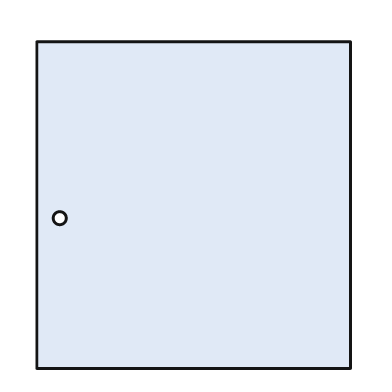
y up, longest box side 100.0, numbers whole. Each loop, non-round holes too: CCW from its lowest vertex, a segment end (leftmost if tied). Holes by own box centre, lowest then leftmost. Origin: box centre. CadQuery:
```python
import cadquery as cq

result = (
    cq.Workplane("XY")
    .moveTo(-48.0, -50.0)
    .lineTo(48.0, -50.0)
    .lineTo(48.0, 50.0)
    .lineTo(-48.0, 50.0)
    .close()
    .moveTo(-41.0, -4.0)
    .circle(2.0)
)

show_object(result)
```